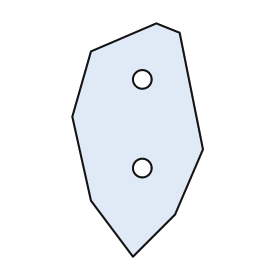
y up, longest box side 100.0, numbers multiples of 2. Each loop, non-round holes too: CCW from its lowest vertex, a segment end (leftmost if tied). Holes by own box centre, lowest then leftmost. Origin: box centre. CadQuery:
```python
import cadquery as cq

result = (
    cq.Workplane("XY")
    .moveTo(-2.0, -50.0)
    .lineTo(16.0, -32.0)
    .lineTo(28.0, -4.0)
    .lineTo(18.0, 46.0)
    .lineTo(8.0, 50.0)
    .lineTo(-20.0, 38.0)
    .lineTo(-28.0, 10.0)
    .lineTo(-20.0, -26.0)
    .close()
    .moveTo(2.0, -12.0)
    .circle(4.0)
    .moveTo(2.0, 26.0)
    .circle(4.0)
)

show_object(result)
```